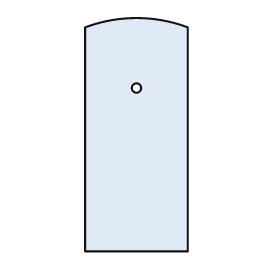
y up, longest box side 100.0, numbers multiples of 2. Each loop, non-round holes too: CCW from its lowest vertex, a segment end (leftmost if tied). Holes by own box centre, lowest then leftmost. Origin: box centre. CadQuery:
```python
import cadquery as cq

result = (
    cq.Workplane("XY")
    .moveTo(-22.0, -50.0)
    .lineTo(22.0, -50.0)
    .lineTo(22.0, 46.0)
    .threePointArc((0.0, 50.0), (-22.0, 46.0))
    .close()
    .moveTo(0.0, 20.0)
    .circle(2.0)
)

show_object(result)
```